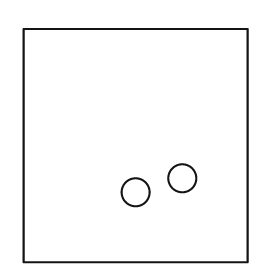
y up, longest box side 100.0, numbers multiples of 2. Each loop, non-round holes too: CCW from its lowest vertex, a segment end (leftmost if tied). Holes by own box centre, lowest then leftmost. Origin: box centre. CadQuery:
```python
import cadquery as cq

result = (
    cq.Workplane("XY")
    .moveTo(-48.0, -50.0)
    .lineTo(48.0, -50.0)
    .lineTo(48.0, 50.0)
    .lineTo(-48.0, 50.0)
    .close()
    .moveTo(0.0, -20.0)
    .circle(6.0)
    .moveTo(20.0, -14.0)
    .circle(6.0)
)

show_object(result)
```